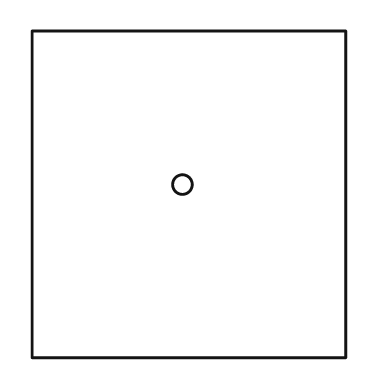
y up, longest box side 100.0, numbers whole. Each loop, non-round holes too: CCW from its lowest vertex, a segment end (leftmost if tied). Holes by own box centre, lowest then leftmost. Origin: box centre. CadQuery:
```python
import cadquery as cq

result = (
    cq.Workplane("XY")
    .moveTo(-48.0, -50.0)
    .lineTo(48.0, -50.0)
    .lineTo(48.0, 50.0)
    .lineTo(-48.0, 50.0)
    .close()
    .moveTo(-2.0, 3.0)
    .circle(3.0)
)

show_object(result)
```